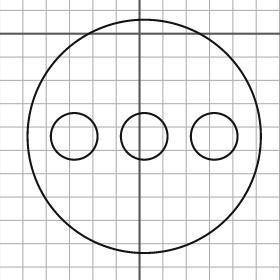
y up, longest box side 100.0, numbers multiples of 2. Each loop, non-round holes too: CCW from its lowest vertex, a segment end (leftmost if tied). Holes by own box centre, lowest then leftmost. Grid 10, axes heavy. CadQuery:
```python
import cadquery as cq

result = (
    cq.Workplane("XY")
    .moveTo(2.0, -44.0)
    .circle(50.0)
    .moveTo(-28.0, -44.0)
    .circle(10.0)
    .moveTo(2.0, -44.0)
    .circle(10.0)
    .moveTo(32.0, -44.0)
    .circle(10.0)
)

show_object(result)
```